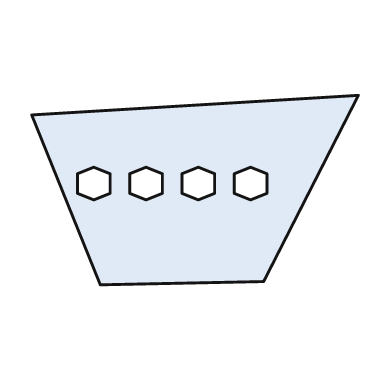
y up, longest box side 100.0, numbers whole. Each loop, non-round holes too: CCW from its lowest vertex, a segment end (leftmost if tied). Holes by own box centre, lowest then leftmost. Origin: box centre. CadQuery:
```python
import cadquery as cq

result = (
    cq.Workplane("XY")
    .moveTo(-29.0, -29.0)
    .lineTo(21.0, -28.0)
    .lineTo(50.0, 29.0)
    .lineTo(-50.0, 23.0)
    .close()
    .moveTo(-31.0, -3.0)
    .lineTo(-26.0, -1.0)
    .lineTo(-26.0, 5.0)
    .lineTo(-31.0, 7.0)
    .lineTo(-36.0, 5.0)
    .lineTo(-36.0, -1.0)
    .close()
    .moveTo(-15.0, -3.0)
    .lineTo(-10.0, -1.0)
    .lineTo(-10.0, 5.0)
    .lineTo(-15.0, 7.0)
    .lineTo(-20.0, 5.0)
    .lineTo(-20.0, -1.0)
    .close()
    .moveTo(1.0, -3.0)
    .lineTo(6.0, -1.0)
    .lineTo(6.0, 5.0)
    .lineTo(1.0, 7.0)
    .lineTo(-4.0, 5.0)
    .lineTo(-4.0, -1.0)
    .close()
    .moveTo(17.0, -3.0)
    .lineTo(22.0, -1.0)
    .lineTo(22.0, 5.0)
    .lineTo(17.0, 7.0)
    .lineTo(12.0, 5.0)
    .lineTo(12.0, -1.0)
    .close()
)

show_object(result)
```